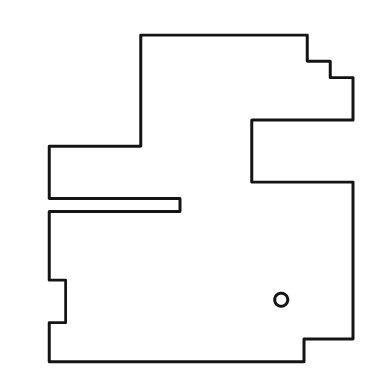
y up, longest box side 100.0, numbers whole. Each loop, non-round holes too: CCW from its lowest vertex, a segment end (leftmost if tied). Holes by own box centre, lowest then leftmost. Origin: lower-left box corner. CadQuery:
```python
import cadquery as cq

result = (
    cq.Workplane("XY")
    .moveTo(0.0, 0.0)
    .lineTo(78.0, 0.0)
    .lineTo(78.0, 7.0)
    .lineTo(93.0, 7.0)
    .lineTo(93.0, 55.0)
    .lineTo(62.0, 55.0)
    .lineTo(62.0, 74.0)
    .lineTo(93.0, 74.0)
    .lineTo(93.0, 87.0)
    .lineTo(86.0, 87.0)
    .lineTo(86.0, 92.0)
    .lineTo(79.0, 92.0)
    .lineTo(79.0, 100.0)
    .lineTo(28.0, 100.0)
    .lineTo(28.0, 66.0)
    .lineTo(0.0, 66.0)
    .lineTo(0.0, 50.0)
    .lineTo(40.0, 50.0)
    .lineTo(40.0, 46.0)
    .lineTo(0.0, 46.0)
    .lineTo(0.0, 25.0)
    .lineTo(5.0, 25.0)
    .lineTo(5.0, 12.0)
    .lineTo(0.0, 12.0)
    .close()
    .moveTo(71.0, 19.0)
    .circle(2.0)
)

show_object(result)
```